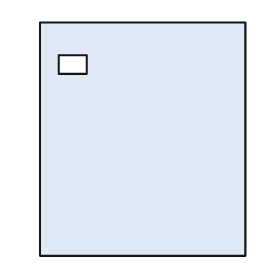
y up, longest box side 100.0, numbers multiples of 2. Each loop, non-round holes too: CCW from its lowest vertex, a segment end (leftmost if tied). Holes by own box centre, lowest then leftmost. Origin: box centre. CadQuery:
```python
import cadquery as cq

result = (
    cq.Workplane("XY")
    .moveTo(-44.0, -50.0)
    .lineTo(44.0, -50.0)
    .lineTo(44.0, 50.0)
    .lineTo(-44.0, 50.0)
    .close()
    .moveTo(-36.0, 28.0)
    .lineTo(-24.0, 28.0)
    .lineTo(-24.0, 36.0)
    .lineTo(-36.0, 36.0)
    .close()
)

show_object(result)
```